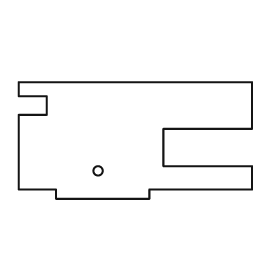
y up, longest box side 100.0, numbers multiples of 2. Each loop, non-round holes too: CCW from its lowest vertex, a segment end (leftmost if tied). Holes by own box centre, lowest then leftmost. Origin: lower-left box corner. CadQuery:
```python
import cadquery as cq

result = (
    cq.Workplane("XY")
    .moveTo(16.0, 0.0)
    .lineTo(56.0, 0.0)
    .lineTo(56.0, 4.0)
    .lineTo(100.0, 4.0)
    .lineTo(100.0, 14.0)
    .lineTo(62.0, 14.0)
    .lineTo(62.0, 30.0)
    .lineTo(100.0, 30.0)
    .lineTo(100.0, 50.0)
    .lineTo(0.0, 50.0)
    .lineTo(0.0, 44.0)
    .lineTo(12.0, 44.0)
    .lineTo(12.0, 36.0)
    .lineTo(0.0, 36.0)
    .lineTo(0.0, 4.0)
    .lineTo(16.0, 4.0)
    .close()
    .moveTo(34.0, 12.0)
    .circle(2.0)
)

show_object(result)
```